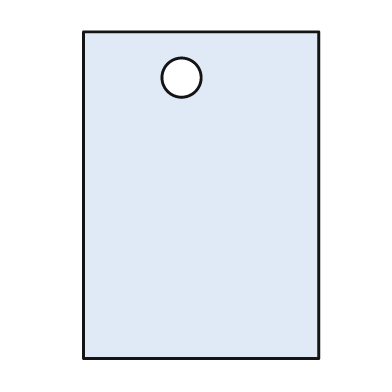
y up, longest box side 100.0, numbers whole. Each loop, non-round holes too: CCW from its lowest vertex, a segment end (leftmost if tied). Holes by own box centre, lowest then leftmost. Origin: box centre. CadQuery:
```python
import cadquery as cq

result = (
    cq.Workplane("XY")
    .moveTo(-36.0, -50.0)
    .lineTo(36.0, -50.0)
    .lineTo(36.0, 50.0)
    .lineTo(-36.0, 50.0)
    .close()
    .moveTo(-6.0, 36.0)
    .circle(6.0)
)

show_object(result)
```